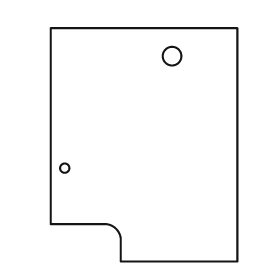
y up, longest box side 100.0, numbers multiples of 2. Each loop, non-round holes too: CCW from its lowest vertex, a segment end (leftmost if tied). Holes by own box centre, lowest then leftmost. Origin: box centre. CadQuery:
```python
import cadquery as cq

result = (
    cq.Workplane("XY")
    .moveTo(-10.0, -50.0)
    .lineTo(40.0, -50.0)
    .lineTo(40.0, 50.0)
    .lineTo(-40.0, 50.0)
    .lineTo(-40.0, -34.0)
    .lineTo(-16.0, -34.0)
    .threePointArc((-12.0, -36.0), (-10.0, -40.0))
    .close()
    .moveTo(-34.0, -10.0)
    .circle(2.0)
    .moveTo(12.0, 38.0)
    .circle(4.0)
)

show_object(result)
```